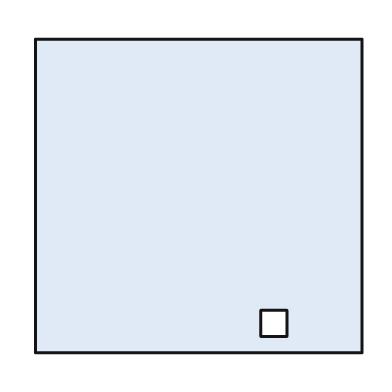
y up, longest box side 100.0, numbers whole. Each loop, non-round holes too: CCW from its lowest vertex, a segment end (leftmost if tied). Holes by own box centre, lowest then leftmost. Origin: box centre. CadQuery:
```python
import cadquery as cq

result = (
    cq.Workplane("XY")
    .moveTo(-50.0, -48.0)
    .lineTo(50.0, -48.0)
    .lineTo(50.0, 48.0)
    .lineTo(-50.0, 48.0)
    .close()
    .moveTo(19.0, -43.0)
    .lineTo(27.0, -43.0)
    .lineTo(27.0, -35.0)
    .lineTo(19.0, -35.0)
    .close()
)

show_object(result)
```